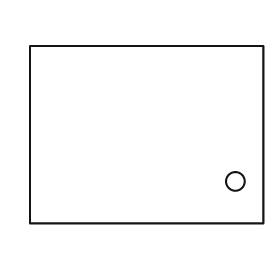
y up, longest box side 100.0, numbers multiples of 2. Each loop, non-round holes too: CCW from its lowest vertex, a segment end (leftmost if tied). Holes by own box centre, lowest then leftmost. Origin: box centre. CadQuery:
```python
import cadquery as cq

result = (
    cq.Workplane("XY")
    .moveTo(-50.0, -38.0)
    .lineTo(50.0, -38.0)
    .lineTo(50.0, 38.0)
    .lineTo(-50.0, 38.0)
    .close()
    .moveTo(38.0, -20.0)
    .circle(4.0)
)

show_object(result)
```